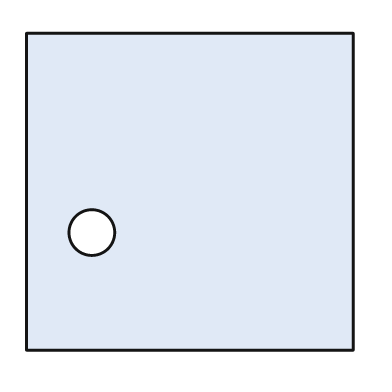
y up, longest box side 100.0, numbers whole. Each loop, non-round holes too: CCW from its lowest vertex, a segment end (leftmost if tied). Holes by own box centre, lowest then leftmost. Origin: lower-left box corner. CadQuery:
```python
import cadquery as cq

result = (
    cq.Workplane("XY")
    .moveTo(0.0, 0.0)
    .lineTo(100.0, 0.0)
    .lineTo(100.0, 97.0)
    .lineTo(0.0, 97.0)
    .close()
    .moveTo(20.0, 36.0)
    .circle(7.0)
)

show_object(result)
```